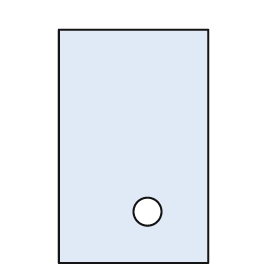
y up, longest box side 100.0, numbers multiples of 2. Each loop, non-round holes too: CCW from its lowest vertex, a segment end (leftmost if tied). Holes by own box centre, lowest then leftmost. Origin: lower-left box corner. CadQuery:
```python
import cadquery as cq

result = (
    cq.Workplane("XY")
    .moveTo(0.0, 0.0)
    .lineTo(64.0, 0.0)
    .lineTo(64.0, 100.0)
    .lineTo(0.0, 100.0)
    .close()
    .moveTo(38.0, 22.0)
    .circle(6.0)
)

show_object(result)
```